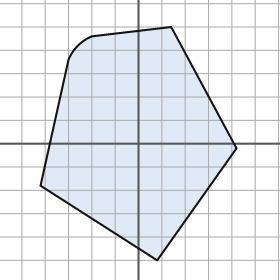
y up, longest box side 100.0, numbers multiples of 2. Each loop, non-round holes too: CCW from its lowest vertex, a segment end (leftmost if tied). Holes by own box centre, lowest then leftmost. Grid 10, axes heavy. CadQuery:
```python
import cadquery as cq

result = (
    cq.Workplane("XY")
    .moveTo(8.0, -50.0)
    .lineTo(42.0, -2.0)
    .lineTo(14.0, 50.0)
    .lineTo(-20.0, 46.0)
    .threePointArc((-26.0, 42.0), (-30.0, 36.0))
    .lineTo(-42.0, -18.0)
    .close()
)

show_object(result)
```